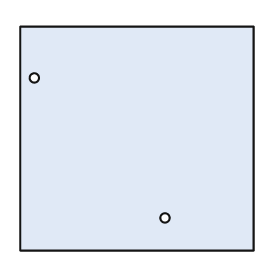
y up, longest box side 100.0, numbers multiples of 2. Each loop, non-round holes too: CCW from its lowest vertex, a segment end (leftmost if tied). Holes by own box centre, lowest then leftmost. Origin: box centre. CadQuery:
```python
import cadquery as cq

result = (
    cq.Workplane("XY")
    .moveTo(-50.0, -48.0)
    .lineTo(50.0, -48.0)
    .lineTo(50.0, 48.0)
    .lineTo(-50.0, 48.0)
    .close()
    .moveTo(12.0, -34.0)
    .circle(2.0)
    .moveTo(-44.0, 26.0)
    .circle(2.0)
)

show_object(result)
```